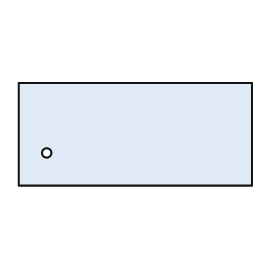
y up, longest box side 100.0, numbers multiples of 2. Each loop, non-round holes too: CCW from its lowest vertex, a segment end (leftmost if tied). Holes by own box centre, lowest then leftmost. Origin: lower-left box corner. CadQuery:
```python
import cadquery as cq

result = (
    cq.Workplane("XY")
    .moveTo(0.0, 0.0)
    .lineTo(100.0, 0.0)
    .lineTo(100.0, 44.0)
    .lineTo(0.0, 44.0)
    .close()
    .moveTo(12.0, 14.0)
    .circle(2.0)
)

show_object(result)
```